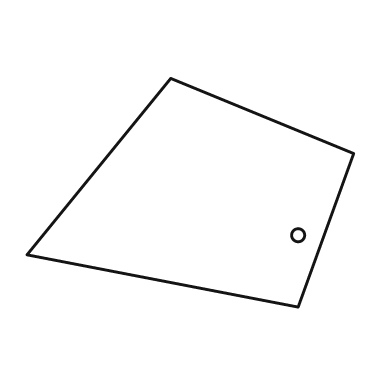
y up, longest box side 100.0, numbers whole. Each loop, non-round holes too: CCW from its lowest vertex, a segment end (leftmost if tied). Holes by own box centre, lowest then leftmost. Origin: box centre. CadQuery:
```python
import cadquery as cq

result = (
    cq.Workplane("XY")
    .moveTo(33.0, -35.0)
    .lineTo(50.0, 12.0)
    .lineTo(-6.0, 35.0)
    .lineTo(-50.0, -19.0)
    .close()
    .moveTo(33.0, -13.0)
    .circle(2.0)
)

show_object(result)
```